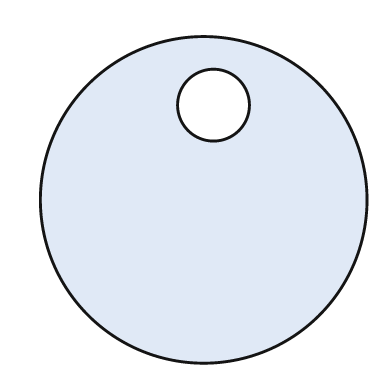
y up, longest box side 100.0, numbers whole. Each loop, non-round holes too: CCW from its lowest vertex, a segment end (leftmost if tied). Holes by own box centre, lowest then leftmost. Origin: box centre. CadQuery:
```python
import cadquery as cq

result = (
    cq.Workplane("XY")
    .moveTo(0.0, 0.0)
    .circle(50.0)
    .moveTo(3.0, 29.0)
    .circle(11.0)
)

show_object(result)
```